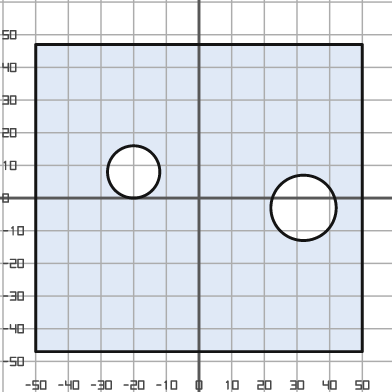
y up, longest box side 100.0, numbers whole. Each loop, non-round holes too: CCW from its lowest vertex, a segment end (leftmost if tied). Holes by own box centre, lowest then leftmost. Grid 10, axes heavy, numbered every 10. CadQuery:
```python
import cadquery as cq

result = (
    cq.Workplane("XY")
    .moveTo(-50.0, -47.0)
    .lineTo(50.0, -47.0)
    .lineTo(50.0, 47.0)
    .lineTo(-50.0, 47.0)
    .close()
    .moveTo(32.0, -3.0)
    .circle(10.0)
    .moveTo(-20.0, 8.0)
    .circle(8.0)
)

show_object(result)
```